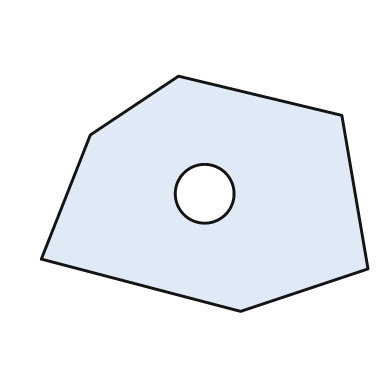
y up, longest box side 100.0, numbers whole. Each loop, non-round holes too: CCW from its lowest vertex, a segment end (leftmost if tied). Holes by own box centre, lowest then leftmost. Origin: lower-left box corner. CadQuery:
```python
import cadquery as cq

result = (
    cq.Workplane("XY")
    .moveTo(61.0, 0.0)
    .lineTo(100.0, 13.0)
    .lineTo(92.0, 60.0)
    .lineTo(42.0, 72.0)
    .lineTo(15.0, 54.0)
    .lineTo(0.0, 16.0)
    .close()
    .moveTo(50.0, 36.0)
    .circle(9.0)
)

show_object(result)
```